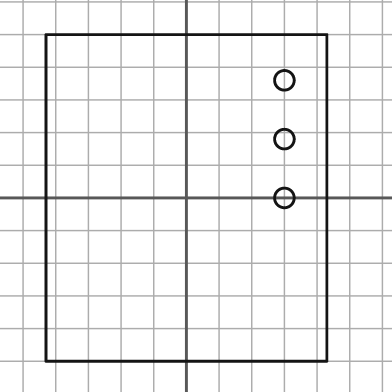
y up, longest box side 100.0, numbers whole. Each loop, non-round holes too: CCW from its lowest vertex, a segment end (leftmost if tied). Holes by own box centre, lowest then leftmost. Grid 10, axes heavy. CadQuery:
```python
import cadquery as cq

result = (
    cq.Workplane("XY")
    .moveTo(-43.0, -50.0)
    .lineTo(43.0, -50.0)
    .lineTo(43.0, 50.0)
    .lineTo(-43.0, 50.0)
    .close()
    .moveTo(30.0, 0.0)
    .circle(3.0)
    .moveTo(30.0, 18.0)
    .circle(3.0)
    .moveTo(30.0, 36.0)
    .circle(3.0)
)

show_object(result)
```